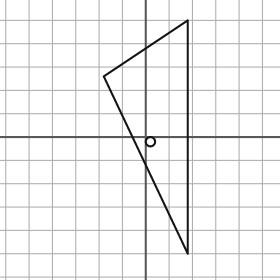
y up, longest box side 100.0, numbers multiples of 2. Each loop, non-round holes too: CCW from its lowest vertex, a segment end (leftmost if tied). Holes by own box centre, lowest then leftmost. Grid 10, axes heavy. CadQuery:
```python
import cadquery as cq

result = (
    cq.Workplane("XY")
    .moveTo(18.0, -50.0)
    .lineTo(18.0, 50.0)
    .lineTo(-18.0, 26.0)
    .close()
    .moveTo(2.0, -2.0)
    .circle(2.0)
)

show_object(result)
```